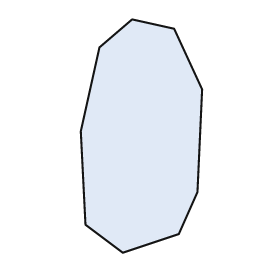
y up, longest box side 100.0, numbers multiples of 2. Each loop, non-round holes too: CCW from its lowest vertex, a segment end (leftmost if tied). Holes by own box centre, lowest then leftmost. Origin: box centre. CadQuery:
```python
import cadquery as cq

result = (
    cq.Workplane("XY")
    .moveTo(-8.0, -50.0)
    .lineTo(16.0, -42.0)
    .lineTo(24.0, -24.0)
    .lineTo(26.0, 20.0)
    .lineTo(14.0, 46.0)
    .lineTo(-4.0, 50.0)
    .lineTo(-18.0, 38.0)
    .lineTo(-26.0, 2.0)
    .lineTo(-24.0, -38.0)
    .close()
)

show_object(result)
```